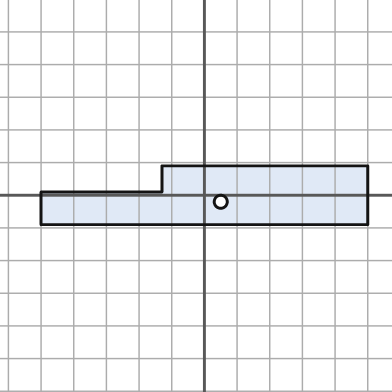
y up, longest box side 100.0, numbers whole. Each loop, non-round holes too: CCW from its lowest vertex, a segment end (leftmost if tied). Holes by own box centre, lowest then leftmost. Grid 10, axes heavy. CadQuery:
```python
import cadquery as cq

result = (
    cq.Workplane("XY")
    .moveTo(-50.0, -9.0)
    .lineTo(50.0, -9.0)
    .lineTo(50.0, 9.0)
    .lineTo(-13.0, 9.0)
    .lineTo(-13.0, 1.0)
    .lineTo(-50.0, 1.0)
    .close()
    .moveTo(5.0, -2.0)
    .circle(2.0)
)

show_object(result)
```